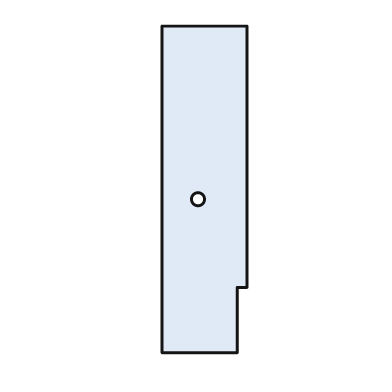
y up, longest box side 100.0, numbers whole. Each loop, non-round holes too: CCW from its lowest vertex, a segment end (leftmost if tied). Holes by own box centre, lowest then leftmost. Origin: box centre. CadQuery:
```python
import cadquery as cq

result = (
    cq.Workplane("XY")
    .moveTo(-13.0, -50.0)
    .lineTo(10.0, -50.0)
    .lineTo(10.0, -30.0)
    .lineTo(13.0, -30.0)
    .lineTo(13.0, 50.0)
    .lineTo(-13.0, 50.0)
    .close()
    .moveTo(-2.0, -3.0)
    .circle(2.0)
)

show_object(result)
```